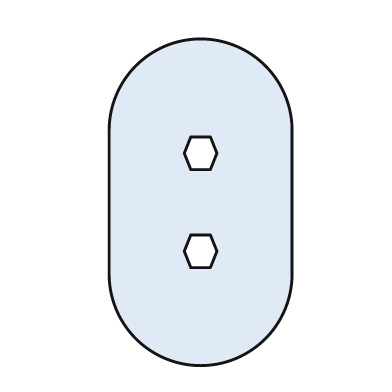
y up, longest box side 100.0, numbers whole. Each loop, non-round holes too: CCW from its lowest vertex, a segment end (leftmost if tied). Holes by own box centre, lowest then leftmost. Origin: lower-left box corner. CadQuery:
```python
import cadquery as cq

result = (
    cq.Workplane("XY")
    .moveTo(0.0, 28.0)
    .threePointArc((28.0, 0.0), (56.0, 28.0))
    .lineTo(56.0, 72.0)
    .threePointArc((28.0, 100.0), (0.0, 72.0))
    .close()
    .moveTo(25.0, 30.0)
    .lineTo(31.0, 30.0)
    .lineTo(33.0, 35.0)
    .lineTo(31.0, 40.0)
    .lineTo(25.0, 40.0)
    .lineTo(23.0, 35.0)
    .close()
    .moveTo(25.0, 60.0)
    .lineTo(31.0, 60.0)
    .lineTo(33.0, 65.0)
    .lineTo(31.0, 70.0)
    .lineTo(25.0, 70.0)
    .lineTo(23.0, 65.0)
    .close()
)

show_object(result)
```